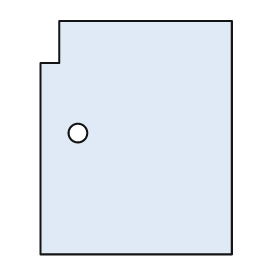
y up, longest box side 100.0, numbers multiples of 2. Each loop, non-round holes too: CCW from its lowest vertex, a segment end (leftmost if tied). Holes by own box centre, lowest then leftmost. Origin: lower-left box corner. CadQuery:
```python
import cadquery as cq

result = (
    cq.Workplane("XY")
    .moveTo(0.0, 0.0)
    .lineTo(82.0, 0.0)
    .lineTo(82.0, 100.0)
    .lineTo(8.0, 100.0)
    .lineTo(8.0, 82.0)
    .lineTo(0.0, 82.0)
    .close()
    .moveTo(16.0, 52.0)
    .circle(4.0)
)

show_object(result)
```